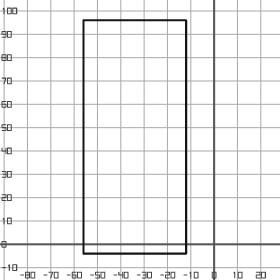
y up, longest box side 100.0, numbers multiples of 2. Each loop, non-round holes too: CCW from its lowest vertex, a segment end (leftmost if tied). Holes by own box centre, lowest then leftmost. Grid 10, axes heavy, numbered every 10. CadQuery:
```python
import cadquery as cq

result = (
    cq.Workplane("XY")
    .moveTo(-56.0, -4.0)
    .lineTo(-12.0, -4.0)
    .lineTo(-12.0, 96.0)
    .lineTo(-56.0, 96.0)
    .close()
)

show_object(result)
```